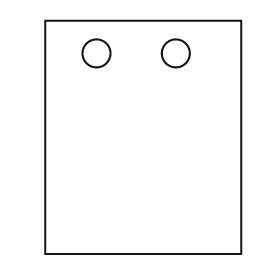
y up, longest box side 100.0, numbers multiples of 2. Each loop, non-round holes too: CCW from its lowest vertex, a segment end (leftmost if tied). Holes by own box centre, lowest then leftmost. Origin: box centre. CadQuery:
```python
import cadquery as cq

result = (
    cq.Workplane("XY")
    .moveTo(-42.0, -50.0)
    .lineTo(42.0, -50.0)
    .lineTo(42.0, 50.0)
    .lineTo(-42.0, 50.0)
    .close()
    .moveTo(-20.0, 36.0)
    .circle(6.0)
    .moveTo(14.0, 36.0)
    .circle(6.0)
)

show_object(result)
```